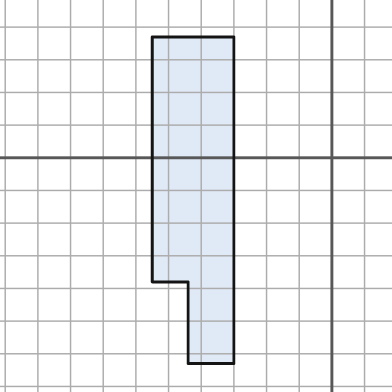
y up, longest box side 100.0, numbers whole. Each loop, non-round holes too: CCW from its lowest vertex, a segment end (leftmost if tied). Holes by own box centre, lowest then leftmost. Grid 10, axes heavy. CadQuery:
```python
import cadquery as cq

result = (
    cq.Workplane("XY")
    .moveTo(-44.0, -63.0)
    .lineTo(-30.0, -63.0)
    .lineTo(-30.0, 37.0)
    .lineTo(-55.0, 37.0)
    .lineTo(-55.0, -38.0)
    .lineTo(-44.0, -38.0)
    .close()
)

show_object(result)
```